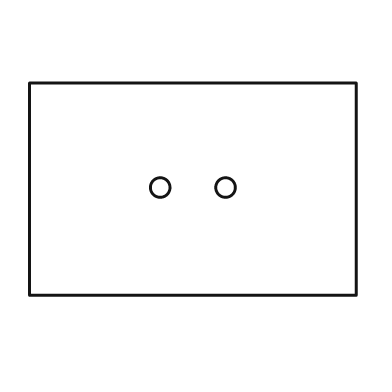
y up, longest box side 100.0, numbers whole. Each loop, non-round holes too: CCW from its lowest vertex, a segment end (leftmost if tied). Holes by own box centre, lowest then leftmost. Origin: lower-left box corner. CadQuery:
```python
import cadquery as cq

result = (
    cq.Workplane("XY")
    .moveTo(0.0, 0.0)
    .lineTo(100.0, 0.0)
    .lineTo(100.0, 65.0)
    .lineTo(0.0, 65.0)
    .close()
    .moveTo(40.0, 33.0)
    .circle(3.0)
    .moveTo(60.0, 33.0)
    .circle(3.0)
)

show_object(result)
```